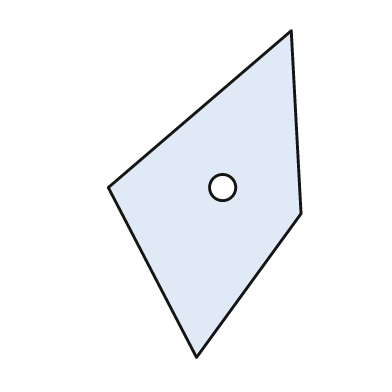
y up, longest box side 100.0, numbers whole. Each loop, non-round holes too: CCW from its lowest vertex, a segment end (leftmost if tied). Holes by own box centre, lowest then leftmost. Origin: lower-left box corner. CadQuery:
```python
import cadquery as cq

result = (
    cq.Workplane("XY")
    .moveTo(27.0, 0.0)
    .lineTo(59.0, 44.0)
    .lineTo(56.0, 100.0)
    .lineTo(0.0, 52.0)
    .close()
    .moveTo(35.0, 52.0)
    .circle(4.0)
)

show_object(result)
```